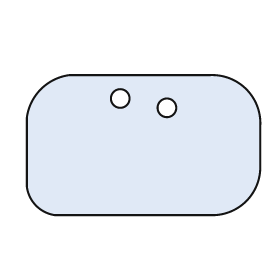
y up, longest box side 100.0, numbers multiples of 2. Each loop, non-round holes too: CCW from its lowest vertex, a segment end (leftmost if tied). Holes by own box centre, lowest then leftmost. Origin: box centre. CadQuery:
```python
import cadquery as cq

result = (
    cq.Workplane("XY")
    .moveTo(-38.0, -30.0)
    .lineTo(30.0, -30.0)
    .threePointArc((44.0, -24.0), (50.0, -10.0))
    .lineTo(50.0, 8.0)
    .threePointArc((44.0, 24.0), (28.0, 30.0))
    .lineTo(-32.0, 30.0)
    .threePointArc((-44.0, 24.0), (-50.0, 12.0))
    .lineTo(-50.0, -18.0)
    .threePointArc((-46.0, -26.0), (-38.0, -30.0))
    .close()
    .moveTo(10.0, 16.0)
    .circle(4.0)
    .moveTo(-10.0, 20.0)
    .circle(4.0)
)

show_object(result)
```